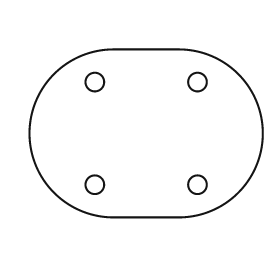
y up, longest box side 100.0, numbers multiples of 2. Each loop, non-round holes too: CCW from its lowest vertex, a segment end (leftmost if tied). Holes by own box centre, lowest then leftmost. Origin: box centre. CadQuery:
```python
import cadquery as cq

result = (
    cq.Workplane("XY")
    .moveTo(-14.0, -36.0)
    .lineTo(14.0, -36.0)
    .threePointArc((50.0, 0.0), (14.0, 36.0))
    .lineTo(-14.0, 36.0)
    .threePointArc((-50.0, 0.0), (-14.0, -36.0))
    .close()
    .moveTo(-22.0, -22.0)
    .circle(4.0)
    .moveTo(22.0, -22.0)
    .circle(4.0)
    .moveTo(-22.0, 22.0)
    .circle(4.0)
    .moveTo(22.0, 22.0)
    .circle(4.0)
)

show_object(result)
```